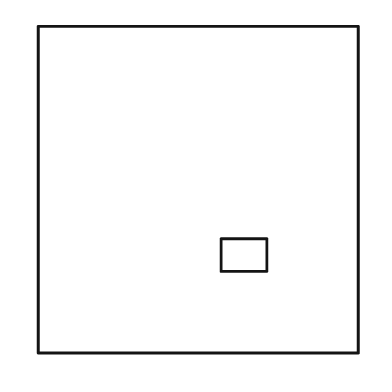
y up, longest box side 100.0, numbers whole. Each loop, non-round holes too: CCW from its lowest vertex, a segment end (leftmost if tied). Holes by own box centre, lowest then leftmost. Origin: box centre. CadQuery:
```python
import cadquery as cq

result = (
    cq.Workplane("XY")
    .moveTo(-49.0, -50.0)
    .lineTo(49.0, -50.0)
    .lineTo(49.0, 50.0)
    .lineTo(-49.0, 50.0)
    .close()
    .moveTo(7.0, -25.0)
    .lineTo(21.0, -25.0)
    .lineTo(21.0, -15.0)
    .lineTo(7.0, -15.0)
    .close()
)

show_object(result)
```